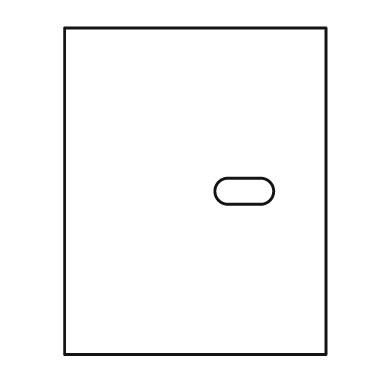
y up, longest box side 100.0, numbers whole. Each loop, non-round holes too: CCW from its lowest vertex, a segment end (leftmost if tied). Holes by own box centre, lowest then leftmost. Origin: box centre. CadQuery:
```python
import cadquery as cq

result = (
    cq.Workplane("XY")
    .moveTo(-40.0, -50.0)
    .lineTo(40.0, -50.0)
    .lineTo(40.0, 50.0)
    .lineTo(-40.0, 50.0)
    .close()
    .moveTo(10.0, -4.0)
    .lineTo(20.0, -4.0)
    .threePointArc((24.0, 0.0), (20.0, 4.0))
    .lineTo(10.0, 4.0)
    .threePointArc((6.0, 0.0), (10.0, -4.0))
    .close()
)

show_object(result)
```